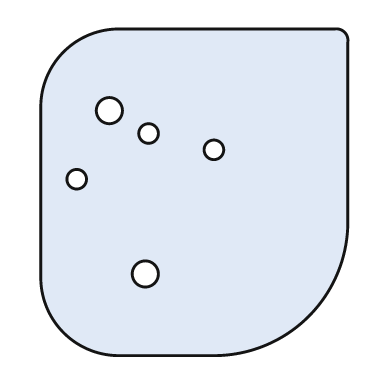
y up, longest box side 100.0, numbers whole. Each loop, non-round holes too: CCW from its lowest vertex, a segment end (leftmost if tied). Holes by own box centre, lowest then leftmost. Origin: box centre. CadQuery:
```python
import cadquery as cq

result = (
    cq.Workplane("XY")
    .moveTo(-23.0, -50.0)
    .lineTo(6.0, -50.0)
    .threePointArc((35.0, -38.0), (47.0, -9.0))
    .lineTo(47.0, 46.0)
    .threePointArc((46.0, 49.0), (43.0, 50.0))
    .lineTo(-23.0, 50.0)
    .threePointArc((-40.0, 43.0), (-47.0, 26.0))
    .lineTo(-47.0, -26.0)
    .threePointArc((-40.0, -43.0), (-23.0, -50.0))
    .close()
    .moveTo(-15.0, -25.0)
    .circle(4.0)
    .moveTo(-36.0, 4.0)
    .circle(3.0)
    .moveTo(6.0, 13.0)
    .circle(3.0)
    .moveTo(-14.0, 18.0)
    .circle(3.0)
    .moveTo(-26.0, 25.0)
    .circle(4.0)
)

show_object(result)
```